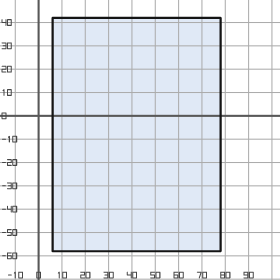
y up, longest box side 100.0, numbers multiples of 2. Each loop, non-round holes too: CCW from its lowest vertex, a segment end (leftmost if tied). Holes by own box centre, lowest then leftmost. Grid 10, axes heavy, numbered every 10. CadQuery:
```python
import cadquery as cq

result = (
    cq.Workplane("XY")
    .moveTo(6.0, -58.0)
    .lineTo(78.0, -58.0)
    .lineTo(78.0, 42.0)
    .lineTo(6.0, 42.0)
    .close()
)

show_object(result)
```